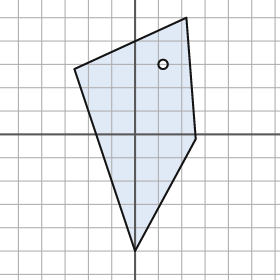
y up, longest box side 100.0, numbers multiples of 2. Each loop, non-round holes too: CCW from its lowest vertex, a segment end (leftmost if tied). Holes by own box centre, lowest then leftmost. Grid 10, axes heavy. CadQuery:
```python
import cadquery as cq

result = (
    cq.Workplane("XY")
    .moveTo(0.0, -50.0)
    .lineTo(26.0, -2.0)
    .lineTo(22.0, 50.0)
    .lineTo(-26.0, 28.0)
    .close()
    .moveTo(12.0, 30.0)
    .circle(2.0)
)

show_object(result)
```